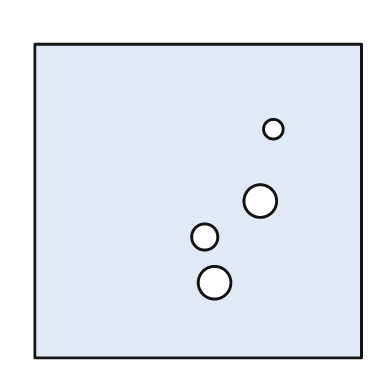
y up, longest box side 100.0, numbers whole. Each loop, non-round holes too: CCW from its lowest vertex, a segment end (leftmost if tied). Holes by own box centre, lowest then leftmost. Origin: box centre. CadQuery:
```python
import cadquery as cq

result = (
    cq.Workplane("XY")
    .moveTo(-50.0, -48.0)
    .lineTo(50.0, -48.0)
    .lineTo(50.0, 48.0)
    .lineTo(-50.0, 48.0)
    .close()
    .moveTo(5.0, -25.0)
    .circle(5.0)
    .moveTo(2.0, -11.0)
    .circle(4.0)
    .moveTo(19.0, 0.0)
    .circle(5.0)
    .moveTo(23.0, 22.0)
    .circle(3.0)
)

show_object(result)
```